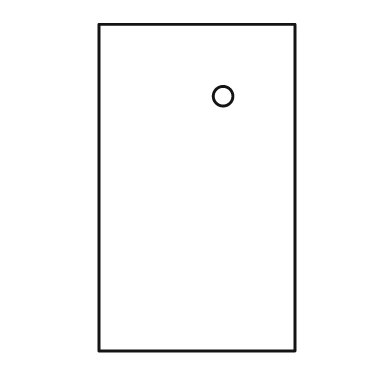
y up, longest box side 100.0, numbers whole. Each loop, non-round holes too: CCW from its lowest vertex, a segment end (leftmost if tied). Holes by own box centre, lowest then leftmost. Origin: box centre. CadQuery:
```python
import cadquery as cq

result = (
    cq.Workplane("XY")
    .moveTo(-30.0, -50.0)
    .lineTo(30.0, -50.0)
    .lineTo(30.0, 50.0)
    .lineTo(-30.0, 50.0)
    .close()
    .moveTo(8.0, 28.0)
    .circle(3.0)
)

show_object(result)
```